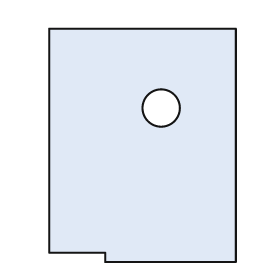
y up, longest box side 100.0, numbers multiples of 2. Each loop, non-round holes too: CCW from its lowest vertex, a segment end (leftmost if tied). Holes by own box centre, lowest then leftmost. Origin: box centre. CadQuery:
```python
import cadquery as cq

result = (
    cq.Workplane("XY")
    .moveTo(-16.0, -50.0)
    .lineTo(40.0, -50.0)
    .lineTo(40.0, 50.0)
    .lineTo(-40.0, 50.0)
    .lineTo(-40.0, -46.0)
    .lineTo(-16.0, -46.0)
    .close()
    .moveTo(8.0, 16.0)
    .circle(8.0)
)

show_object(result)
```